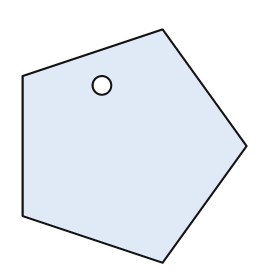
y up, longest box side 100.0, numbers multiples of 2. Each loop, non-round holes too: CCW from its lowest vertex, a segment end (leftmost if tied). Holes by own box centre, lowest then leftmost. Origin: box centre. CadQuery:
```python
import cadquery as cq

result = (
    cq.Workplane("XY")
    .moveTo(12.0, -50.0)
    .lineTo(48.0, 0.0)
    .lineTo(12.0, 50.0)
    .lineTo(-48.0, 30.0)
    .lineTo(-48.0, -30.0)
    .close()
    .moveTo(-14.0, 26.0)
    .circle(4.0)
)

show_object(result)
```